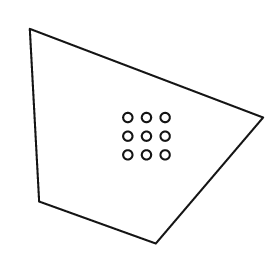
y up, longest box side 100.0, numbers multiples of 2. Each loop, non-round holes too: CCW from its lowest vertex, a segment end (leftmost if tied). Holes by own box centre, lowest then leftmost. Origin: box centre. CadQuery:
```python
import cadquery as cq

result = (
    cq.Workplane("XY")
    .moveTo(4.0, -46.0)
    .lineTo(50.0, 8.0)
    .lineTo(-50.0, 46.0)
    .lineTo(-46.0, -28.0)
    .close()
    .moveTo(-8.0, -8.0)
    .circle(2.0)
    .moveTo(0.0, -8.0)
    .circle(2.0)
    .moveTo(8.0, -8.0)
    .circle(2.0)
    .moveTo(-8.0, 0.0)
    .circle(2.0)
    .moveTo(0.0, 0.0)
    .circle(2.0)
    .moveTo(8.0, 0.0)
    .circle(2.0)
    .moveTo(-8.0, 8.0)
    .circle(2.0)
    .moveTo(0.0, 8.0)
    .circle(2.0)
    .moveTo(8.0, 8.0)
    .circle(2.0)
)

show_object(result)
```